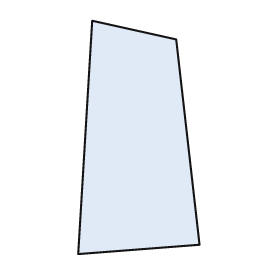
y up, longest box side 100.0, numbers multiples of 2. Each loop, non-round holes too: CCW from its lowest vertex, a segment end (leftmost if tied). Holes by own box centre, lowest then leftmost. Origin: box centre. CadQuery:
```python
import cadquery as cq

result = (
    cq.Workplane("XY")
    .moveTo(-26.0, -50.0)
    .lineTo(26.0, -46.0)
    .lineTo(16.0, 42.0)
    .lineTo(-20.0, 50.0)
    .close()
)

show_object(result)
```